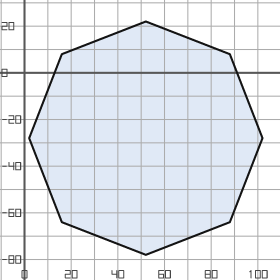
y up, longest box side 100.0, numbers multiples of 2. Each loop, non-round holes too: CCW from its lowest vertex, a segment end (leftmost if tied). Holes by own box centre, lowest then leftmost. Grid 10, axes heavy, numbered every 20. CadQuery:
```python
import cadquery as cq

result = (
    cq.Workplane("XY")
    .moveTo(52.0, -78.0)
    .lineTo(88.0, -64.0)
    .lineTo(102.0, -28.0)
    .lineTo(88.0, 8.0)
    .lineTo(52.0, 22.0)
    .lineTo(16.0, 8.0)
    .lineTo(2.0, -28.0)
    .lineTo(16.0, -64.0)
    .close()
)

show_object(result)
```